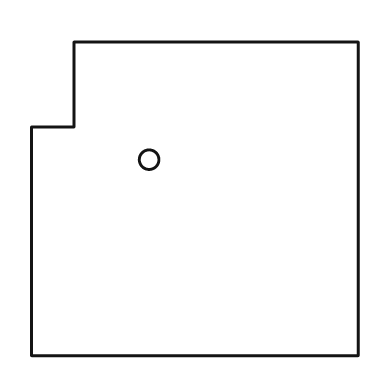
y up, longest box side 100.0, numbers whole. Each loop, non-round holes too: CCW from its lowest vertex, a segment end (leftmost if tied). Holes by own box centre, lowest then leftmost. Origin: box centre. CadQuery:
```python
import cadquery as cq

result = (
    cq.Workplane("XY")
    .moveTo(-50.0, -48.0)
    .lineTo(50.0, -48.0)
    .lineTo(50.0, 48.0)
    .lineTo(-37.0, 48.0)
    .lineTo(-37.0, 22.0)
    .lineTo(-50.0, 22.0)
    .close()
    .moveTo(-14.0, 12.0)
    .circle(3.0)
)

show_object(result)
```